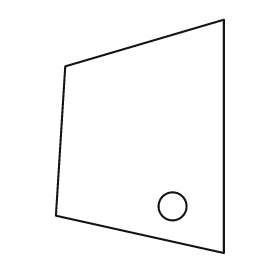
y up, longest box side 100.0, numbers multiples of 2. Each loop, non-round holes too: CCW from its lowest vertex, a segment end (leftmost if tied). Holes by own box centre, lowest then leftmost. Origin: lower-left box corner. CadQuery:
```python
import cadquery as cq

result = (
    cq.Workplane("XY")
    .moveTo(72.0, 0.0)
    .lineTo(72.0, 100.0)
    .lineTo(4.0, 80.0)
    .lineTo(0.0, 16.0)
    .close()
    .moveTo(50.0, 20.0)
    .circle(6.0)
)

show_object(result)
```